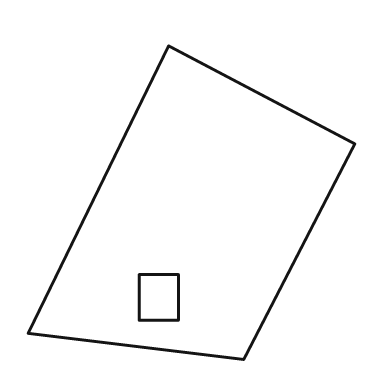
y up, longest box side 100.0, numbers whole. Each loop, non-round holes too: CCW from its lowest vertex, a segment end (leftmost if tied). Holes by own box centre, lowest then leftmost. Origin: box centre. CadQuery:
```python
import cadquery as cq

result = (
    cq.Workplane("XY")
    .moveTo(16.0, -48.0)
    .lineTo(50.0, 18.0)
    .lineTo(-7.0, 48.0)
    .lineTo(-50.0, -40.0)
    .close()
    .moveTo(-16.0, -36.0)
    .lineTo(-4.0, -36.0)
    .lineTo(-4.0, -22.0)
    .lineTo(-16.0, -22.0)
    .close()
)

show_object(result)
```